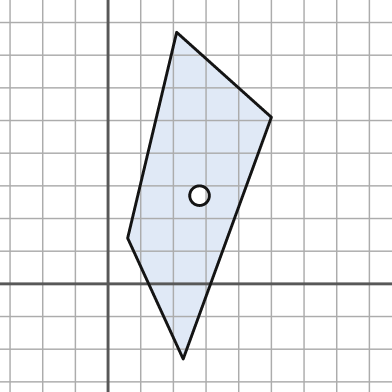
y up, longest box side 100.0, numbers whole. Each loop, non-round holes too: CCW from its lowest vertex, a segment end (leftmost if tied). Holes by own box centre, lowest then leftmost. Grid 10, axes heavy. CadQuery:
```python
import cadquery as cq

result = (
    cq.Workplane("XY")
    .moveTo(23.0, -23.0)
    .lineTo(50.0, 51.0)
    .lineTo(21.0, 77.0)
    .lineTo(6.0, 14.0)
    .close()
    .moveTo(28.0, 27.0)
    .circle(3.0)
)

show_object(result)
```